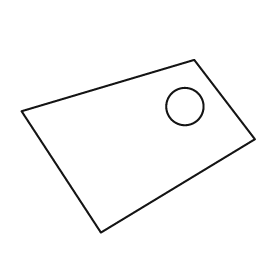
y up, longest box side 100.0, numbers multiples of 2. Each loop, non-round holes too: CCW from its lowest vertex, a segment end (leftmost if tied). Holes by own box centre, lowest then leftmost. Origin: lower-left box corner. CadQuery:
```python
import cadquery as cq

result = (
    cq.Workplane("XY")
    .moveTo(34.0, 0.0)
    .lineTo(100.0, 40.0)
    .lineTo(74.0, 74.0)
    .lineTo(0.0, 52.0)
    .close()
    .moveTo(70.0, 54.0)
    .circle(8.0)
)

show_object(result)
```